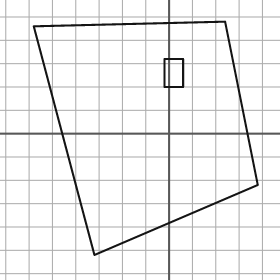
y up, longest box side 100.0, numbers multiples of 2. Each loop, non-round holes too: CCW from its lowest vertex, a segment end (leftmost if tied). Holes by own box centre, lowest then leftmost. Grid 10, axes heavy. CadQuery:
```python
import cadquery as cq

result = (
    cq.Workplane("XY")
    .moveTo(-32.0, -52.0)
    .lineTo(38.0, -22.0)
    .lineTo(24.0, 48.0)
    .lineTo(-58.0, 46.0)
    .close()
    .moveTo(-2.0, 20.0)
    .lineTo(6.0, 20.0)
    .lineTo(6.0, 32.0)
    .lineTo(-2.0, 32.0)
    .close()
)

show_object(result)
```